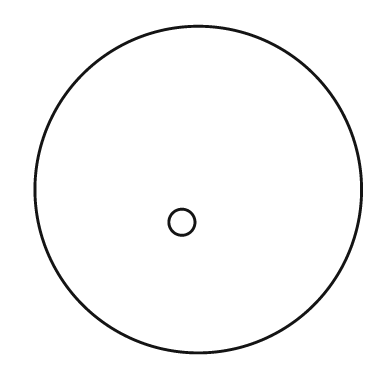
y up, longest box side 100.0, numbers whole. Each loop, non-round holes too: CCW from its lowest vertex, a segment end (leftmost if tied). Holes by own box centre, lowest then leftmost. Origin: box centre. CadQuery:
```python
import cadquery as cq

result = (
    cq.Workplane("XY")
    .moveTo(0.0, 0.0)
    .circle(50.0)
    .moveTo(-5.0, -10.0)
    .circle(4.0)
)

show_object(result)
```